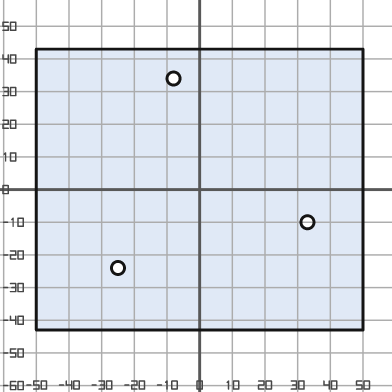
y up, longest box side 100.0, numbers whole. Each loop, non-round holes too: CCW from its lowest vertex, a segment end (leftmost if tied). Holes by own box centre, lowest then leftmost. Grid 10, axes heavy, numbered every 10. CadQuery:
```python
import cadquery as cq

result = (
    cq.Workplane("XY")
    .moveTo(-50.0, -43.0)
    .lineTo(50.0, -43.0)
    .lineTo(50.0, 43.0)
    .lineTo(-50.0, 43.0)
    .close()
    .moveTo(-25.0, -24.0)
    .circle(2.0)
    .moveTo(33.0, -10.0)
    .circle(2.0)
    .moveTo(-8.0, 34.0)
    .circle(2.0)
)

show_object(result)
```